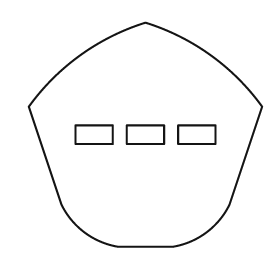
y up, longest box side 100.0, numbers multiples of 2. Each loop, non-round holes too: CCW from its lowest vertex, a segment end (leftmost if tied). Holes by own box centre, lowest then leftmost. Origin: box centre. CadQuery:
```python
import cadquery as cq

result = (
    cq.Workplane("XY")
    .moveTo(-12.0, -48.0)
    .lineTo(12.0, -48.0)
    .threePointArc((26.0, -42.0), (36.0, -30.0))
    .lineTo(50.0, 12.0)
    .threePointArc((28.0, 34.0), (0.0, 48.0))
    .threePointArc((-28.0, 34.0), (-50.0, 12.0))
    .lineTo(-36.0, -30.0)
    .threePointArc((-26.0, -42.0), (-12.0, -48.0))
    .close()
    .moveTo(-30.0, -4.0)
    .lineTo(-14.0, -4.0)
    .lineTo(-14.0, 4.0)
    .lineTo(-30.0, 4.0)
    .close()
    .moveTo(-8.0, -4.0)
    .lineTo(8.0, -4.0)
    .lineTo(8.0, 4.0)
    .lineTo(-8.0, 4.0)
    .close()
    .moveTo(14.0, -4.0)
    .lineTo(30.0, -4.0)
    .lineTo(30.0, 4.0)
    .lineTo(14.0, 4.0)
    .close()
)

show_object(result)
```